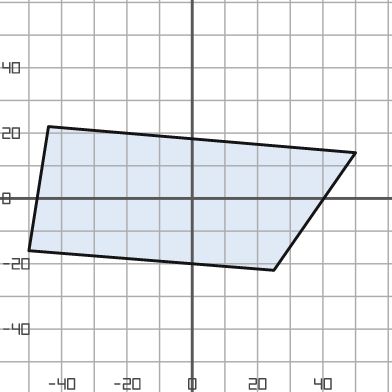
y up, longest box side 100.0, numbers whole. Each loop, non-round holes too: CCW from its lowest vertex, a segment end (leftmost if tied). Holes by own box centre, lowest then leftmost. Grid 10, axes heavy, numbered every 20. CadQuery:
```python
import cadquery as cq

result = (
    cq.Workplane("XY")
    .moveTo(25.0, -22.0)
    .lineTo(50.0, 14.0)
    .lineTo(-44.0, 22.0)
    .lineTo(-50.0, -16.0)
    .close()
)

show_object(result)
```